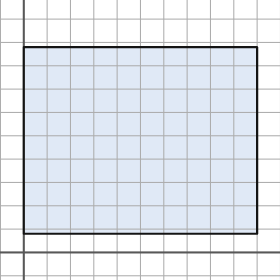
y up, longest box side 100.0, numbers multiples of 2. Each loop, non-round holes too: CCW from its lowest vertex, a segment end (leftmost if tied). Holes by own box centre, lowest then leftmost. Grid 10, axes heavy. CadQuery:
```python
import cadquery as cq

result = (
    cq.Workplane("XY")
    .moveTo(0.0, 8.0)
    .lineTo(100.0, 8.0)
    .lineTo(100.0, 88.0)
    .lineTo(0.0, 88.0)
    .close()
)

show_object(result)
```